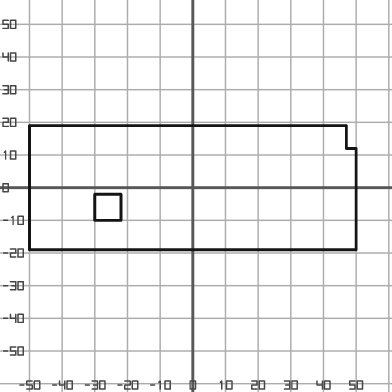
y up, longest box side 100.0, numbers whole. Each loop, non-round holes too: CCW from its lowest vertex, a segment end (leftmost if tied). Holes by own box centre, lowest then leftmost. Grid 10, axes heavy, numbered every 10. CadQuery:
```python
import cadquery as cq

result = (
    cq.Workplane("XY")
    .moveTo(-50.0, -19.0)
    .lineTo(50.0, -19.0)
    .lineTo(50.0, 12.0)
    .lineTo(47.0, 12.0)
    .lineTo(47.0, 19.0)
    .lineTo(-50.0, 19.0)
    .close()
    .moveTo(-30.0, -10.0)
    .lineTo(-22.0, -10.0)
    .lineTo(-22.0, -2.0)
    .lineTo(-30.0, -2.0)
    .close()
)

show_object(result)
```